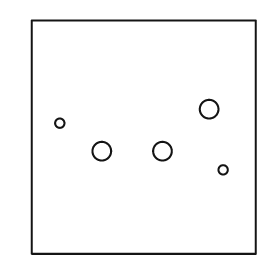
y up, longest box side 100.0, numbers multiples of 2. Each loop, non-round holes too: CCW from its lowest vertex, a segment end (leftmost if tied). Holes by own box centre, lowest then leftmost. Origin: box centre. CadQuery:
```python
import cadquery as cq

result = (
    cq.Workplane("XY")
    .moveTo(-48.0, -50.0)
    .lineTo(48.0, -50.0)
    .lineTo(48.0, 50.0)
    .lineTo(-48.0, 50.0)
    .close()
    .moveTo(34.0, -14.0)
    .circle(2.0)
    .moveTo(-18.0, -6.0)
    .circle(4.0)
    .moveTo(8.0, -6.0)
    .circle(4.0)
    .moveTo(-36.0, 6.0)
    .circle(2.0)
    .moveTo(28.0, 12.0)
    .circle(4.0)
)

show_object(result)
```